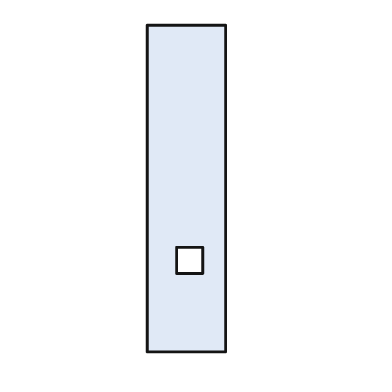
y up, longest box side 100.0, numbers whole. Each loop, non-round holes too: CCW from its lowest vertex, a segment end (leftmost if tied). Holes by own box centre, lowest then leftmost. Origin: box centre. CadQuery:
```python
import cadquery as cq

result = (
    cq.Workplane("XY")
    .moveTo(-12.0, -50.0)
    .lineTo(12.0, -50.0)
    .lineTo(12.0, 50.0)
    .lineTo(-12.0, 50.0)
    .close()
    .moveTo(-3.0, -26.0)
    .lineTo(5.0, -26.0)
    .lineTo(5.0, -18.0)
    .lineTo(-3.0, -18.0)
    .close()
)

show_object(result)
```